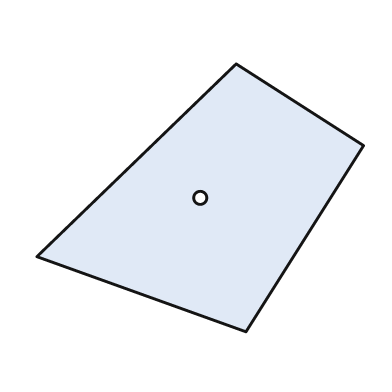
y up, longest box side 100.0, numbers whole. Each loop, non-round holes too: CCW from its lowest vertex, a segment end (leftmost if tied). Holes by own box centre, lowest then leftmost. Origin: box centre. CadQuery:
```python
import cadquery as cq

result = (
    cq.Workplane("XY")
    .moveTo(14.0, -41.0)
    .lineTo(50.0, 16.0)
    .lineTo(11.0, 41.0)
    .lineTo(-50.0, -18.0)
    .close()
    .moveTo(0.0, 0.0)
    .circle(2.0)
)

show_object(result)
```